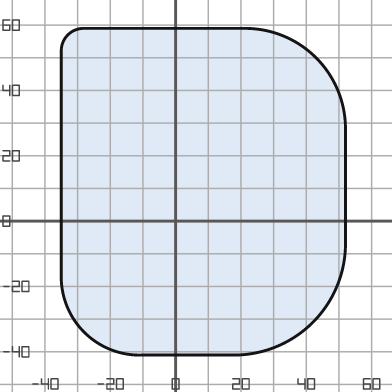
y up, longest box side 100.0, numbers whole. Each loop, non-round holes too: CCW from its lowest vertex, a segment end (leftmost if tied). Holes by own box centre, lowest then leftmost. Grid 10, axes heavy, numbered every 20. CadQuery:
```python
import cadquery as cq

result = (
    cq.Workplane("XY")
    .moveTo(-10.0, -41.0)
    .lineTo(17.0, -41.0)
    .threePointArc((42.0, -31.0), (52.0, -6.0))
    .lineTo(52.0, 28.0)
    .threePointArc((43.0, 50.0), (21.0, 59.0))
    .lineTo(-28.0, 59.0)
    .threePointArc((-33.0, 57.0), (-35.0, 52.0))
    .lineTo(-35.0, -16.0)
    .threePointArc((-28.0, -34.0), (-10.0, -41.0))
    .close()
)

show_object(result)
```